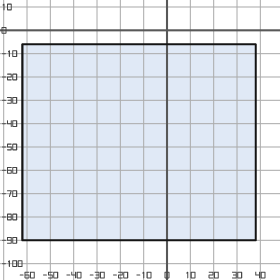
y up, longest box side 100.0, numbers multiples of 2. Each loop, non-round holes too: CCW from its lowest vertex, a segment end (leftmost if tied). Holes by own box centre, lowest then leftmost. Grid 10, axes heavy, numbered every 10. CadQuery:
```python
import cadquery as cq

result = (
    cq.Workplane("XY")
    .moveTo(-62.0, -90.0)
    .lineTo(38.0, -90.0)
    .lineTo(38.0, -6.0)
    .lineTo(-62.0, -6.0)
    .close()
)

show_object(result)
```